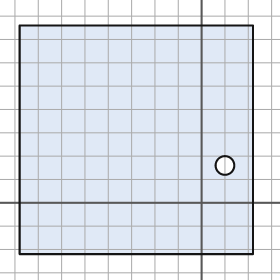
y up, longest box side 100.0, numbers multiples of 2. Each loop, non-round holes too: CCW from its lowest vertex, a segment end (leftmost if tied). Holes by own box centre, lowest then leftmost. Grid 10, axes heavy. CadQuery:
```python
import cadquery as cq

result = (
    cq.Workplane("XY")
    .moveTo(-78.0, -22.0)
    .lineTo(22.0, -22.0)
    .lineTo(22.0, 76.0)
    .lineTo(-78.0, 76.0)
    .close()
    .moveTo(10.0, 16.0)
    .circle(4.0)
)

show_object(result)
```